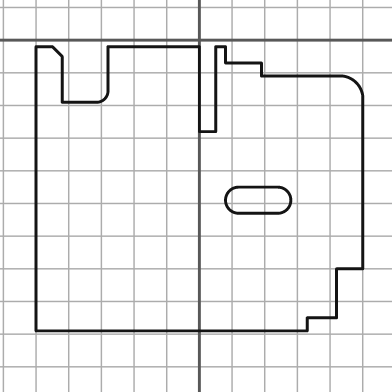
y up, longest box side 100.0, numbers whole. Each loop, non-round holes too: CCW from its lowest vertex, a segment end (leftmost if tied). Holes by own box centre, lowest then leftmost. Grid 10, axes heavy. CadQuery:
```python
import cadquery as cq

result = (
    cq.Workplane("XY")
    .moveTo(-50.0, -89.0)
    .lineTo(33.0, -89.0)
    .lineTo(33.0, -85.0)
    .lineTo(42.0, -85.0)
    .lineTo(42.0, -70.0)
    .lineTo(50.0, -70.0)
    .lineTo(50.0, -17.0)
    .threePointArc((48.0, -13.0), (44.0, -11.0))
    .lineTo(19.0, -11.0)
    .lineTo(19.0, -7.0)
    .lineTo(8.0, -7.0)
    .lineTo(8.0, -2.0)
    .lineTo(5.0, -2.0)
    .lineTo(5.0, -28.0)
    .lineTo(0.0, -28.0)
    .lineTo(0.0, -2.0)
    .lineTo(-28.0, -2.0)
    .lineTo(-28.0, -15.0)
    .threePointArc((-29.0, -18.0), (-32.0, -19.0))
    .lineTo(-42.0, -19.0)
    .lineTo(-42.0, -5.0)
    .lineTo(-45.0, -2.0)
    .lineTo(-50.0, -2.0)
    .close()
    .moveTo(12.0, -53.0)
    .lineTo(24.0, -53.0)
    .threePointArc((28.0, -49.0), (24.0, -45.0))
    .lineTo(12.0, -45.0)
    .threePointArc((8.0, -49.0), (12.0, -53.0))
    .close()
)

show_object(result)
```